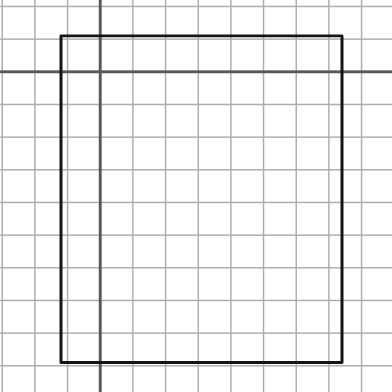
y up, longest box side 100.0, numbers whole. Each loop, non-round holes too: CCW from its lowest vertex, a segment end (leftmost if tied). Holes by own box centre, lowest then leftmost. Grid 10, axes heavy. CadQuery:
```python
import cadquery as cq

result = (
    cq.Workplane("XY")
    .moveTo(-12.0, -89.0)
    .lineTo(74.0, -89.0)
    .lineTo(74.0, 11.0)
    .lineTo(-12.0, 11.0)
    .close()
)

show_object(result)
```